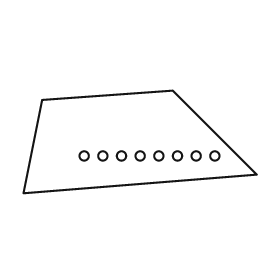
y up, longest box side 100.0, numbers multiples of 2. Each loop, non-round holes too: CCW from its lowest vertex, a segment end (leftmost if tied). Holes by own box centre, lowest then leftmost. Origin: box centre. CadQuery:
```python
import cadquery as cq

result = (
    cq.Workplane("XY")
    .moveTo(-50.0, -22.0)
    .lineTo(50.0, -14.0)
    .lineTo(14.0, 22.0)
    .lineTo(-42.0, 18.0)
    .close()
    .moveTo(-24.0, -6.0)
    .circle(2.0)
    .moveTo(-16.0, -6.0)
    .circle(2.0)
    .moveTo(-8.0, -6.0)
    .circle(2.0)
    .moveTo(0.0, -6.0)
    .circle(2.0)
    .moveTo(8.0, -6.0)
    .circle(2.0)
    .moveTo(16.0, -6.0)
    .circle(2.0)
    .moveTo(24.0, -6.0)
    .circle(2.0)
    .moveTo(32.0, -6.0)
    .circle(2.0)
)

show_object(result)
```